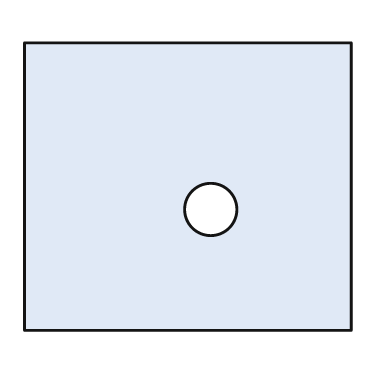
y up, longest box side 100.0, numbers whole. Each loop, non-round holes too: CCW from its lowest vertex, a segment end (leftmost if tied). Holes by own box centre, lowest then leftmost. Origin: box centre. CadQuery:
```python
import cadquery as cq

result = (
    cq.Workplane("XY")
    .moveTo(-50.0, -44.0)
    .lineTo(50.0, -44.0)
    .lineTo(50.0, 44.0)
    .lineTo(-50.0, 44.0)
    .close()
    .moveTo(7.0, -7.0)
    .circle(8.0)
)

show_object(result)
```